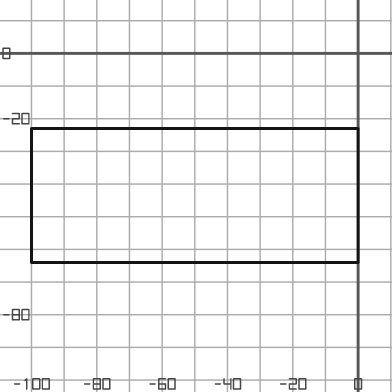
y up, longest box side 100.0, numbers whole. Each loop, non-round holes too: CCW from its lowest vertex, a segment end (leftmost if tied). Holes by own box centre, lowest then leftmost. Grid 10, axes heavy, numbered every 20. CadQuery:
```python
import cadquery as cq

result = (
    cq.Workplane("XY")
    .moveTo(-100.0, -64.0)
    .lineTo(0.0, -64.0)
    .lineTo(0.0, -23.0)
    .lineTo(-100.0, -23.0)
    .close()
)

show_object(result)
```